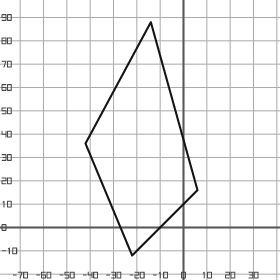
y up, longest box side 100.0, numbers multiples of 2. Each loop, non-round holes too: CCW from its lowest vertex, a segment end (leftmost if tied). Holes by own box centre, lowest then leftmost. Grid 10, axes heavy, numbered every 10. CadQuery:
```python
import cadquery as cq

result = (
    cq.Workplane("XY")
    .moveTo(-22.0, -12.0)
    .lineTo(6.0, 16.0)
    .lineTo(-14.0, 88.0)
    .lineTo(-42.0, 36.0)
    .close()
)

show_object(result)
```